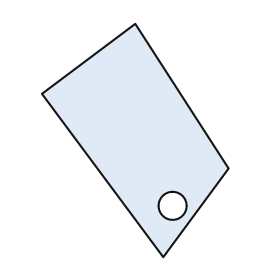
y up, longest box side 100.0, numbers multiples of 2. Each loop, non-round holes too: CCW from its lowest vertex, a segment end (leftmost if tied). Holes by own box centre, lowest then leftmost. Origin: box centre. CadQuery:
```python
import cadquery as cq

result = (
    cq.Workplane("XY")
    .moveTo(12.0, -50.0)
    .lineTo(40.0, -12.0)
    .lineTo(0.0, 50.0)
    .lineTo(-40.0, 20.0)
    .close()
    .moveTo(16.0, -28.0)
    .circle(6.0)
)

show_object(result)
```